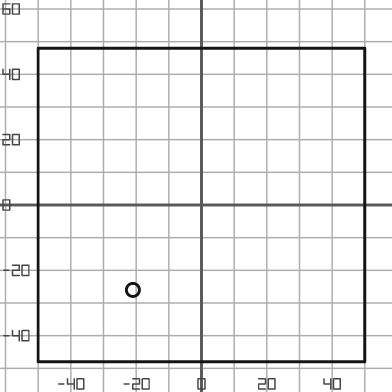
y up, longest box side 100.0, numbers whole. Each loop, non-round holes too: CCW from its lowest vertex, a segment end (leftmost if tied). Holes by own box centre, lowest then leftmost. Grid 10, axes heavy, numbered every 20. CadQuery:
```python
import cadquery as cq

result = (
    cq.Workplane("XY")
    .moveTo(-50.0, -48.0)
    .lineTo(50.0, -48.0)
    .lineTo(50.0, 48.0)
    .lineTo(-50.0, 48.0)
    .close()
    .moveTo(-21.0, -26.0)
    .circle(2.0)
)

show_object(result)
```